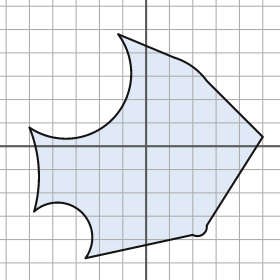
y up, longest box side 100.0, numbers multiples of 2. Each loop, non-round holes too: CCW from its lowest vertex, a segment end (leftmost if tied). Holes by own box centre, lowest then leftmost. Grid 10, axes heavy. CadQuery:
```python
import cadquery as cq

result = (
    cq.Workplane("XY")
    .moveTo(-26.0, -48.0)
    .lineTo(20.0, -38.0)
    .threePointArc((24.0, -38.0), (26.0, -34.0))
    .lineTo(50.0, 4.0)
    .lineTo(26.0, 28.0)
    .threePointArc((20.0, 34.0), (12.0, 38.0))
    .lineTo(-12.0, 48.0)
    .threePointArc((-14.0, 12.0), (-50.0, 8.0))
    .threePointArc((-46.0, -10.0), (-48.0, -28.0))
    .threePointArc((-28.0, -28.0), (-26.0, -48.0))
    .close()
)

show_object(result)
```